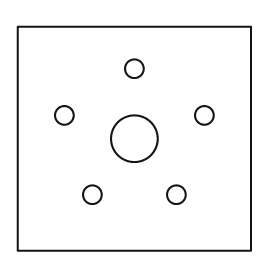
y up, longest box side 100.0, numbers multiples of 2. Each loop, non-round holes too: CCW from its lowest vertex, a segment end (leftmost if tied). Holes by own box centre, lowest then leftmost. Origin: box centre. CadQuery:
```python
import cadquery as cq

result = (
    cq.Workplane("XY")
    .moveTo(-50.0, -48.0)
    .lineTo(50.0, -48.0)
    .lineTo(50.0, 48.0)
    .lineTo(-50.0, 48.0)
    .close()
    .moveTo(-18.0, -24.0)
    .circle(4.0)
    .moveTo(18.0, -24.0)
    .circle(4.0)
    .moveTo(0.0, 0.0)
    .circle(10.0)
    .moveTo(-30.0, 10.0)
    .circle(4.0)
    .moveTo(30.0, 10.0)
    .circle(4.0)
    .moveTo(0.0, 30.0)
    .circle(4.0)
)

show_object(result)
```